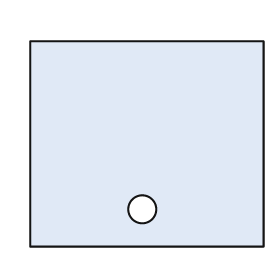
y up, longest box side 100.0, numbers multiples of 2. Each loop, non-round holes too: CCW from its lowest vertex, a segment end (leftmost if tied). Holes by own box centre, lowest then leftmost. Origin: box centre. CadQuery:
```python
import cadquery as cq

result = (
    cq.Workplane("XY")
    .moveTo(-50.0, -44.0)
    .lineTo(50.0, -44.0)
    .lineTo(50.0, 44.0)
    .lineTo(-50.0, 44.0)
    .close()
    .moveTo(-2.0, -28.0)
    .circle(6.0)
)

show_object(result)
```